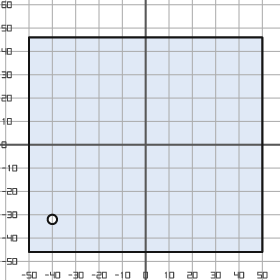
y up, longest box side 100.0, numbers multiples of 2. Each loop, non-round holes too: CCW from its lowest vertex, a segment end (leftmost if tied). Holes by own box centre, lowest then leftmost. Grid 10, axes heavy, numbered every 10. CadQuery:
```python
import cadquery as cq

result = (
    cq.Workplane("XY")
    .moveTo(-50.0, -46.0)
    .lineTo(50.0, -46.0)
    .lineTo(50.0, 46.0)
    .lineTo(-50.0, 46.0)
    .close()
    .moveTo(-40.0, -32.0)
    .circle(2.0)
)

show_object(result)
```